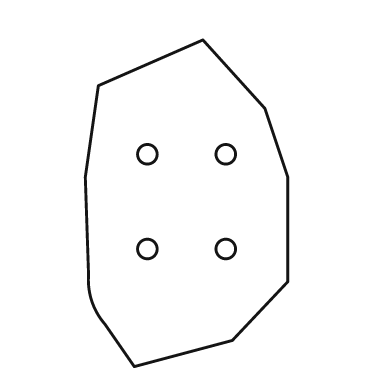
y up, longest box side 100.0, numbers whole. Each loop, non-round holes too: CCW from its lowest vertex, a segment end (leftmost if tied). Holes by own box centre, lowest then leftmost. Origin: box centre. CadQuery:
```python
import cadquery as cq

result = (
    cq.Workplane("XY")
    .moveTo(-16.0, -50.0)
    .lineTo(14.0, -42.0)
    .lineTo(31.0, -24.0)
    .lineTo(31.0, 8.0)
    .lineTo(24.0, 29.0)
    .lineTo(5.0, 50.0)
    .lineTo(-27.0, 36.0)
    .lineTo(-31.0, 8.0)
    .lineTo(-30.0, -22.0)
    .threePointArc((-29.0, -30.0), (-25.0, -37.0))
    .close()
    .moveTo(-12.0, -14.0)
    .circle(3.0)
    .moveTo(12.0, -14.0)
    .circle(3.0)
    .moveTo(-12.0, 15.0)
    .circle(3.0)
    .moveTo(12.0, 15.0)
    .circle(3.0)
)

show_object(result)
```